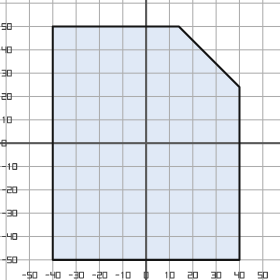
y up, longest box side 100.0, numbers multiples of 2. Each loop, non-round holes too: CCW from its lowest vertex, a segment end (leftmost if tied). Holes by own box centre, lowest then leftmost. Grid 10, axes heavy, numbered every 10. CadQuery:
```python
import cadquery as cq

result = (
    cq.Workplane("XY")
    .moveTo(-40.0, -50.0)
    .lineTo(40.0, -50.0)
    .lineTo(40.0, 24.0)
    .lineTo(14.0, 50.0)
    .lineTo(-40.0, 50.0)
    .close()
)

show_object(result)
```